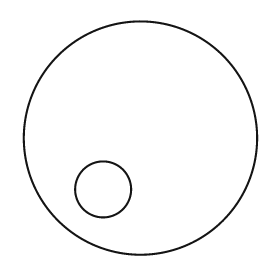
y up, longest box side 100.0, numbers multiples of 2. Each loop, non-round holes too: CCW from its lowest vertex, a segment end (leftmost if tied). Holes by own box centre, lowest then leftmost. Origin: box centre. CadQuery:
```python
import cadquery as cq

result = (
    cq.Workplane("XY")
    .moveTo(0.0, 0.0)
    .circle(50.0)
    .moveTo(-16.0, -22.0)
    .circle(12.0)
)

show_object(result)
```